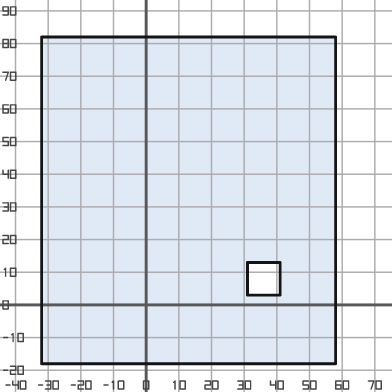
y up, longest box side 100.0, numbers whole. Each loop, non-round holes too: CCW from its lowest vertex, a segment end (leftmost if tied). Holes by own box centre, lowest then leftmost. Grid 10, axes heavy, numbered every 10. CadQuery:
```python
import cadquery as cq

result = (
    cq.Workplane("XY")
    .moveTo(-32.0, -18.0)
    .lineTo(58.0, -18.0)
    .lineTo(58.0, 82.0)
    .lineTo(-32.0, 82.0)
    .close()
    .moveTo(31.0, 3.0)
    .lineTo(41.0, 3.0)
    .lineTo(41.0, 13.0)
    .lineTo(31.0, 13.0)
    .close()
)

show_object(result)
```